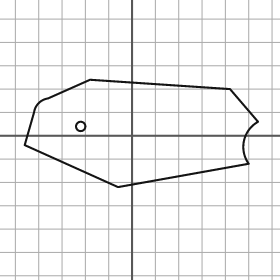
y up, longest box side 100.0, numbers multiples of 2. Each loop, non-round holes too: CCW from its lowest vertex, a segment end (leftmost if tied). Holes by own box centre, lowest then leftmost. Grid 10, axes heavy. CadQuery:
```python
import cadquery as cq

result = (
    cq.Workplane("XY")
    .moveTo(-6.0, -22.0)
    .lineTo(50.0, -12.0)
    .threePointArc((48.0, -2.0), (54.0, 6.0))
    .lineTo(42.0, 20.0)
    .lineTo(-18.0, 24.0)
    .lineTo(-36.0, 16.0)
    .threePointArc((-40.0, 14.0), (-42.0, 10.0))
    .lineTo(-46.0, -4.0)
    .close()
    .moveTo(-22.0, 4.0)
    .circle(2.0)
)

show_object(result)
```